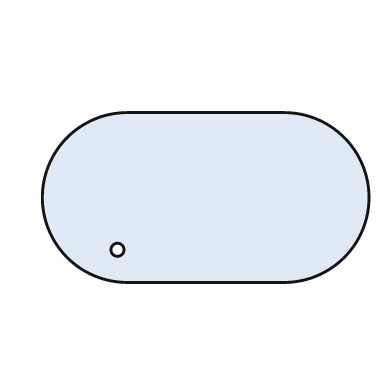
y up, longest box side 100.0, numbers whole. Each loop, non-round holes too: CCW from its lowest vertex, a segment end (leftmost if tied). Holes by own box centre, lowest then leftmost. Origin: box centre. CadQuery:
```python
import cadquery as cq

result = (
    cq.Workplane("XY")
    .moveTo(-24.0, -26.0)
    .lineTo(24.0, -26.0)
    .threePointArc((50.0, 0.0), (24.0, 26.0))
    .lineTo(-24.0, 26.0)
    .threePointArc((-50.0, 0.0), (-24.0, -26.0))
    .close()
    .moveTo(-27.0, -16.0)
    .circle(2.0)
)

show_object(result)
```